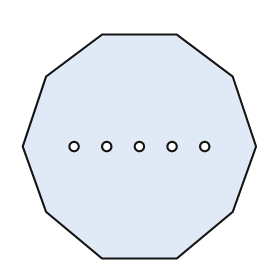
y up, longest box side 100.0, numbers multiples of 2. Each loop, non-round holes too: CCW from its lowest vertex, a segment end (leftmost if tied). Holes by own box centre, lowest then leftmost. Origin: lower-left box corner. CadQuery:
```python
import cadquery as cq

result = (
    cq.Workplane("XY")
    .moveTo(34.0, 0.0)
    .lineTo(66.0, 0.0)
    .lineTo(90.0, 20.0)
    .lineTo(100.0, 48.0)
    .lineTo(90.0, 78.0)
    .lineTo(66.0, 96.0)
    .lineTo(34.0, 96.0)
    .lineTo(10.0, 78.0)
    .lineTo(0.0, 48.0)
    .lineTo(10.0, 20.0)
    .close()
    .moveTo(22.0, 48.0)
    .circle(2.0)
    .moveTo(36.0, 48.0)
    .circle(2.0)
    .moveTo(50.0, 48.0)
    .circle(2.0)
    .moveTo(64.0, 48.0)
    .circle(2.0)
    .moveTo(78.0, 48.0)
    .circle(2.0)
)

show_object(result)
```